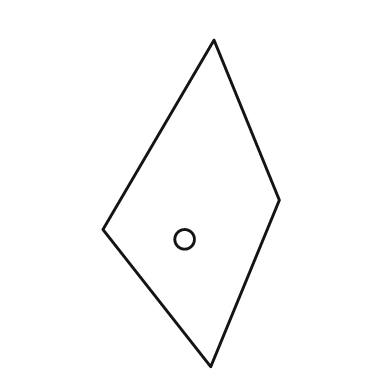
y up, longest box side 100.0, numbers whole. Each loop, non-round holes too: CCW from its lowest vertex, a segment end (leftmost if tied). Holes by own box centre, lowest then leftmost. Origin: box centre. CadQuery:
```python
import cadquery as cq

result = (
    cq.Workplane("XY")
    .moveTo(6.0, -50.0)
    .lineTo(27.0, 1.0)
    .lineTo(7.0, 50.0)
    .lineTo(-27.0, -8.0)
    .close()
    .moveTo(-2.0, -11.0)
    .circle(3.0)
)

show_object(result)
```